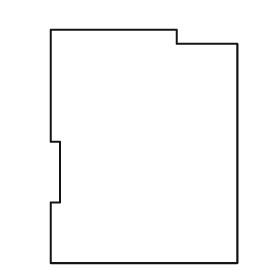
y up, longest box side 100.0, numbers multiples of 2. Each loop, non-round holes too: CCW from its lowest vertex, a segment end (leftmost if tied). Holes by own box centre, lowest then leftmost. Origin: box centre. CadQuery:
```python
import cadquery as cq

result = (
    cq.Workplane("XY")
    .moveTo(-40.0, -50.0)
    .lineTo(40.0, -50.0)
    .lineTo(40.0, 44.0)
    .lineTo(14.0, 44.0)
    .lineTo(14.0, 50.0)
    .lineTo(-40.0, 50.0)
    .lineTo(-40.0, 2.0)
    .lineTo(-36.0, 2.0)
    .lineTo(-36.0, -24.0)
    .lineTo(-40.0, -24.0)
    .close()
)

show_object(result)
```